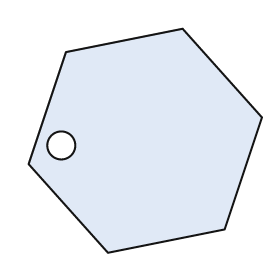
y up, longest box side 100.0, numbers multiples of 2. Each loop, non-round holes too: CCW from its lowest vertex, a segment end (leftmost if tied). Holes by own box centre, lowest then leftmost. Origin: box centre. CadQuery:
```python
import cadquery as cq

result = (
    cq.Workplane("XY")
    .moveTo(-16.0, -48.0)
    .lineTo(34.0, -38.0)
    .lineTo(50.0, 10.0)
    .lineTo(16.0, 48.0)
    .lineTo(-34.0, 38.0)
    .lineTo(-50.0, -10.0)
    .close()
    .moveTo(-36.0, -2.0)
    .circle(6.0)
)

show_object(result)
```